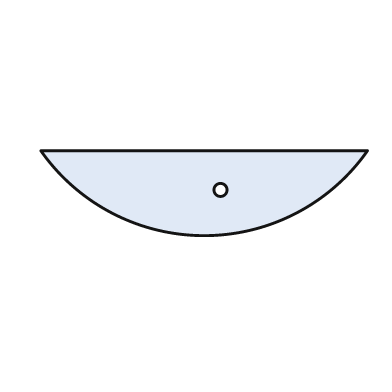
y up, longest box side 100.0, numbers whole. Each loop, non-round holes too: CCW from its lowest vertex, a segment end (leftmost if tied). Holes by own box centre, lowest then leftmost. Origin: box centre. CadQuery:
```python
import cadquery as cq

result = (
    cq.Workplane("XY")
    .moveTo(-50.0, 13.0)
    .threePointArc((0.0, -13.0), (50.0, 13.0))
    .close()
    .moveTo(5.0, 1.0)
    .circle(2.0)
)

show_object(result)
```